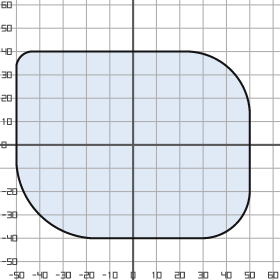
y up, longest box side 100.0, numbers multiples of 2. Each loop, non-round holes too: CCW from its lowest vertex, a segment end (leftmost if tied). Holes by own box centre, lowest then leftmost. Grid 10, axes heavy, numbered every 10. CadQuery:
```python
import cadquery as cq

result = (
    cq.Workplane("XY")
    .moveTo(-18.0, -40.0)
    .lineTo(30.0, -40.0)
    .threePointArc((44.0, -34.0), (50.0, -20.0))
    .lineTo(50.0, 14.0)
    .threePointArc((42.0, 32.0), (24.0, 40.0))
    .lineTo(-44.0, 40.0)
    .threePointArc((-48.0, 38.0), (-50.0, 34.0))
    .lineTo(-50.0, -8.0)
    .threePointArc((-40.0, -30.0), (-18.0, -40.0))
    .close()
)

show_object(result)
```